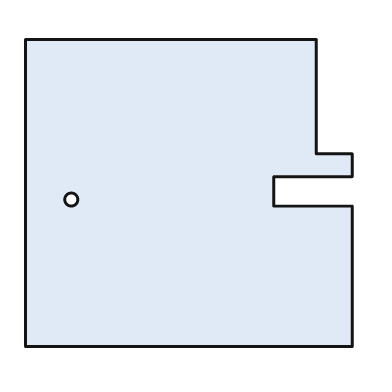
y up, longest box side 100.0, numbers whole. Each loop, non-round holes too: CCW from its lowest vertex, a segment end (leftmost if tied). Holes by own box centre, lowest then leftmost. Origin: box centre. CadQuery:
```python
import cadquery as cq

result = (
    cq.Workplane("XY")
    .moveTo(-50.0, -47.0)
    .lineTo(50.0, -47.0)
    .lineTo(50.0, -4.0)
    .lineTo(26.0, -4.0)
    .lineTo(26.0, 5.0)
    .lineTo(50.0, 5.0)
    .lineTo(50.0, 12.0)
    .lineTo(39.0, 12.0)
    .lineTo(39.0, 47.0)
    .lineTo(-50.0, 47.0)
    .close()
    .moveTo(-36.0, -2.0)
    .circle(2.0)
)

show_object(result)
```